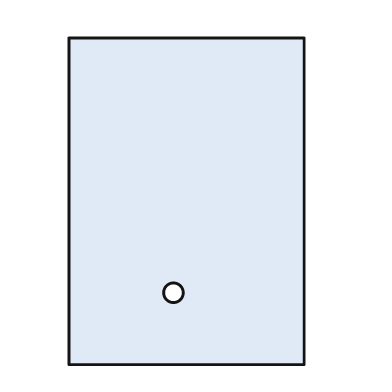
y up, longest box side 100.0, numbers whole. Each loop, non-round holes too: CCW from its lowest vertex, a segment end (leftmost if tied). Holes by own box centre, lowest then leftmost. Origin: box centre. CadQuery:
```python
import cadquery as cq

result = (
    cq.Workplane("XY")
    .moveTo(-36.0, -50.0)
    .lineTo(36.0, -50.0)
    .lineTo(36.0, 50.0)
    .lineTo(-36.0, 50.0)
    .close()
    .moveTo(-4.0, -28.0)
    .circle(3.0)
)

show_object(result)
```